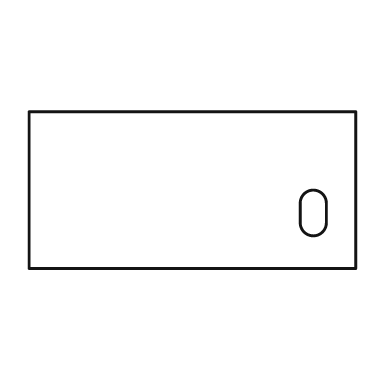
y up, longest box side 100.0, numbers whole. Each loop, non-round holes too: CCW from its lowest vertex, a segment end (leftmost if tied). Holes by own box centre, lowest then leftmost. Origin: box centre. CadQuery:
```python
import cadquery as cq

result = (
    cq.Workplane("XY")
    .moveTo(-50.0, -24.0)
    .lineTo(50.0, -24.0)
    .lineTo(50.0, 24.0)
    .lineTo(-50.0, 24.0)
    .close()
    .moveTo(33.0, -10.0)
    .threePointArc((37.0, -14.0), (41.0, -10.0))
    .lineTo(41.0, -4.0)
    .threePointArc((37.0, 0.0), (33.0, -4.0))
    .close()
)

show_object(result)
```